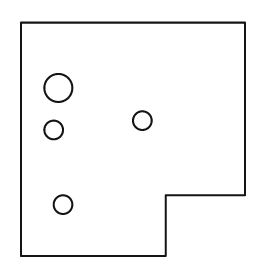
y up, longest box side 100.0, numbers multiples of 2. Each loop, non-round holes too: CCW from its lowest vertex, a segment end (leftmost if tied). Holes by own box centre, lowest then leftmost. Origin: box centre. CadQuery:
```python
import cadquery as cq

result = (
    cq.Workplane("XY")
    .moveTo(-48.0, -50.0)
    .lineTo(14.0, -50.0)
    .lineTo(14.0, -24.0)
    .lineTo(48.0, -24.0)
    .lineTo(48.0, 50.0)
    .lineTo(-48.0, 50.0)
    .close()
    .moveTo(-30.0, -28.0)
    .circle(4.0)
    .moveTo(-34.0, 4.0)
    .circle(4.0)
    .moveTo(4.0, 8.0)
    .circle(4.0)
    .moveTo(-32.0, 22.0)
    .circle(6.0)
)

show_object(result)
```